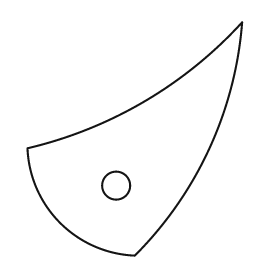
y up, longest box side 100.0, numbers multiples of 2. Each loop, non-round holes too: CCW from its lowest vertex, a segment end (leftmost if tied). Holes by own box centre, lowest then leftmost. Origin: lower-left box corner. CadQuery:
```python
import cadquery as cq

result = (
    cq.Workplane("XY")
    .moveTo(46.0, 0.0)
    .threePointArc((78.0, 46.0), (92.0, 100.0))
    .threePointArc((50.0, 66.0), (0.0, 46.0))
    .threePointArc((14.0, 14.0), (46.0, 0.0))
    .close()
    .moveTo(38.0, 30.0)
    .circle(6.0)
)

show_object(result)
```